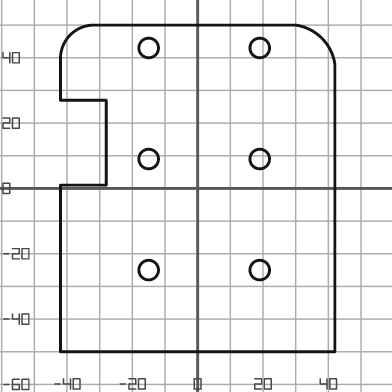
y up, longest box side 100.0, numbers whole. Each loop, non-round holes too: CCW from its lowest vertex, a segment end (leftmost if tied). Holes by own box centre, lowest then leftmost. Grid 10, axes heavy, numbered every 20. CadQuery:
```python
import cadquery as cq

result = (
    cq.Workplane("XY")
    .moveTo(-42.0, -50.0)
    .lineTo(42.0, -50.0)
    .lineTo(42.0, 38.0)
    .threePointArc((38.0, 46.0), (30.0, 50.0))
    .lineTo(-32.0, 50.0)
    .threePointArc((-39.0, 47.0), (-42.0, 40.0))
    .lineTo(-42.0, 27.0)
    .lineTo(-28.0, 27.0)
    .lineTo(-28.0, 1.0)
    .lineTo(-42.0, 1.0)
    .close()
    .moveTo(-15.0, -25.0)
    .circle(3.0)
    .moveTo(19.0, -25.0)
    .circle(3.0)
    .moveTo(-15.0, 9.0)
    .circle(3.0)
    .moveTo(19.0, 9.0)
    .circle(3.0)
    .moveTo(-15.0, 43.0)
    .circle(3.0)
    .moveTo(19.0, 43.0)
    .circle(3.0)
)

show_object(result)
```